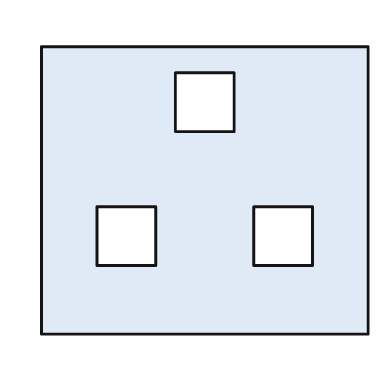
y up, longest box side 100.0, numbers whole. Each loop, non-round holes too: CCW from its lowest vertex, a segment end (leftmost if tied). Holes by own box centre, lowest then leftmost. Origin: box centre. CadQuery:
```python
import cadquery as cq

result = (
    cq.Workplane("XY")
    .moveTo(-50.0, -44.0)
    .lineTo(50.0, -44.0)
    .lineTo(50.0, 44.0)
    .lineTo(-50.0, 44.0)
    .close()
    .moveTo(-33.0, -23.0)
    .lineTo(-15.0, -23.0)
    .lineTo(-15.0, -5.0)
    .lineTo(-33.0, -5.0)
    .close()
    .moveTo(15.0, -23.0)
    .lineTo(33.0, -23.0)
    .lineTo(33.0, -5.0)
    .lineTo(15.0, -5.0)
    .close()
    .moveTo(-9.0, 18.0)
    .lineTo(9.0, 18.0)
    .lineTo(9.0, 36.0)
    .lineTo(-9.0, 36.0)
    .close()
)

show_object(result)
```